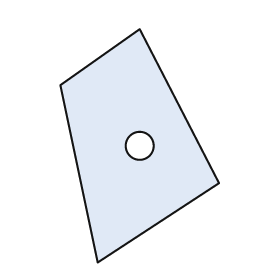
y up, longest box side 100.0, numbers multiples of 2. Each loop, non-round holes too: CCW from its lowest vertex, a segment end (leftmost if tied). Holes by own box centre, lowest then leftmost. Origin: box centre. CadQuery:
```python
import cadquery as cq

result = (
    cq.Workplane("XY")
    .moveTo(-18.0, -50.0)
    .lineTo(34.0, -16.0)
    .lineTo(0.0, 50.0)
    .lineTo(-34.0, 26.0)
    .close()
    .moveTo(0.0, 0.0)
    .circle(6.0)
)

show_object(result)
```